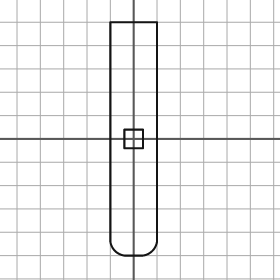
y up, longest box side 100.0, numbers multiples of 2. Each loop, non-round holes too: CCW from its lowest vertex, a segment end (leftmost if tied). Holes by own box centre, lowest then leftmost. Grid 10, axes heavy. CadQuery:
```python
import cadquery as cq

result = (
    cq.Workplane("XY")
    .moveTo(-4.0, -50.0)
    .lineTo(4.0, -50.0)
    .threePointArc((8.0, -48.0), (10.0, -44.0))
    .lineTo(10.0, 50.0)
    .lineTo(-10.0, 50.0)
    .lineTo(-10.0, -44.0)
    .threePointArc((-8.0, -48.0), (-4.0, -50.0))
    .close()
    .moveTo(-4.0, -4.0)
    .lineTo(4.0, -4.0)
    .lineTo(4.0, 4.0)
    .lineTo(-4.0, 4.0)
    .close()
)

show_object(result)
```